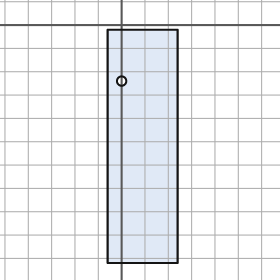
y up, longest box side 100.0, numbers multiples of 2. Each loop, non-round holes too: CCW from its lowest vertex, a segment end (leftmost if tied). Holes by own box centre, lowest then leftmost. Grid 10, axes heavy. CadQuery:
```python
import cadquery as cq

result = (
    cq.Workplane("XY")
    .moveTo(-6.0, -102.0)
    .lineTo(24.0, -102.0)
    .lineTo(24.0, -2.0)
    .lineTo(-6.0, -2.0)
    .close()
    .moveTo(0.0, -24.0)
    .circle(2.0)
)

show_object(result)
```